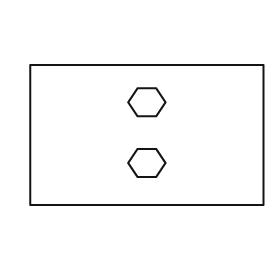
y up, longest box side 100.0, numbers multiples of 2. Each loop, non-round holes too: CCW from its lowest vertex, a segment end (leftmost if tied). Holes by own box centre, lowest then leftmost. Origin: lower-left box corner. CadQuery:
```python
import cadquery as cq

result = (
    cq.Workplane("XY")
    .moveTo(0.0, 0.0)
    .lineTo(100.0, 0.0)
    .lineTo(100.0, 60.0)
    .lineTo(0.0, 60.0)
    .close()
    .moveTo(46.0, 12.0)
    .lineTo(54.0, 12.0)
    .lineTo(58.0, 18.0)
    .lineTo(54.0, 24.0)
    .lineTo(46.0, 24.0)
    .lineTo(42.0, 18.0)
    .close()
    .moveTo(46.0, 38.0)
    .lineTo(54.0, 38.0)
    .lineTo(58.0, 44.0)
    .lineTo(54.0, 50.0)
    .lineTo(46.0, 50.0)
    .lineTo(42.0, 44.0)
    .close()
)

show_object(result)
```